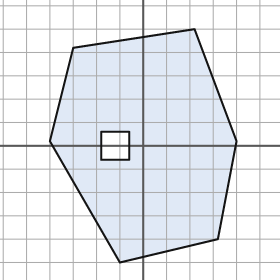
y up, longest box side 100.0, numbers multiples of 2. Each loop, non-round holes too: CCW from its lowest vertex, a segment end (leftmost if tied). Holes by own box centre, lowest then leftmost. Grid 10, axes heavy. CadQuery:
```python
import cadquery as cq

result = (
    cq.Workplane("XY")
    .moveTo(-10.0, -50.0)
    .lineTo(32.0, -40.0)
    .lineTo(40.0, 2.0)
    .lineTo(22.0, 50.0)
    .lineTo(-30.0, 42.0)
    .lineTo(-40.0, 2.0)
    .close()
    .moveTo(-18.0, -6.0)
    .lineTo(-6.0, -6.0)
    .lineTo(-6.0, 6.0)
    .lineTo(-18.0, 6.0)
    .close()
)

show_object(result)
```